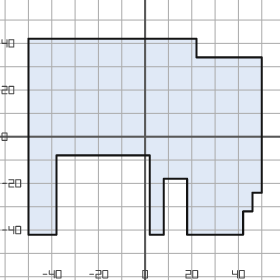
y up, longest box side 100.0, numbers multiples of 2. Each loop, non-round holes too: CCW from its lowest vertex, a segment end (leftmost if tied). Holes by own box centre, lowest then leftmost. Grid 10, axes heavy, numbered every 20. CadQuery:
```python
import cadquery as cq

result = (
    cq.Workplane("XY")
    .moveTo(-50.0, -42.0)
    .lineTo(-38.0, -42.0)
    .lineTo(-38.0, -8.0)
    .lineTo(2.0, -8.0)
    .lineTo(2.0, -42.0)
    .lineTo(8.0, -42.0)
    .lineTo(8.0, -18.0)
    .lineTo(18.0, -18.0)
    .lineTo(18.0, -42.0)
    .lineTo(42.0, -42.0)
    .lineTo(42.0, -32.0)
    .lineTo(46.0, -32.0)
    .lineTo(46.0, -24.0)
    .lineTo(50.0, -24.0)
    .lineTo(50.0, 34.0)
    .lineTo(22.0, 34.0)
    .lineTo(22.0, 42.0)
    .lineTo(-50.0, 42.0)
    .close()
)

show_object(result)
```